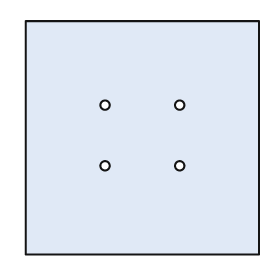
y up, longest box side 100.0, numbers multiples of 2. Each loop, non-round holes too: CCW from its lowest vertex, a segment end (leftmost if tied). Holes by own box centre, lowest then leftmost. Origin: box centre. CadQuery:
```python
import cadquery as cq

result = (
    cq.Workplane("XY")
    .moveTo(-50.0, -50.0)
    .lineTo(50.0, -50.0)
    .lineTo(50.0, 50.0)
    .lineTo(-50.0, 50.0)
    .close()
    .moveTo(-16.0, -12.0)
    .circle(2.0)
    .moveTo(16.0, -12.0)
    .circle(2.0)
    .moveTo(-16.0, 14.0)
    .circle(2.0)
    .moveTo(16.0, 14.0)
    .circle(2.0)
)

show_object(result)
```